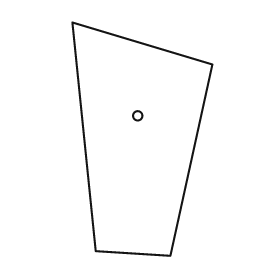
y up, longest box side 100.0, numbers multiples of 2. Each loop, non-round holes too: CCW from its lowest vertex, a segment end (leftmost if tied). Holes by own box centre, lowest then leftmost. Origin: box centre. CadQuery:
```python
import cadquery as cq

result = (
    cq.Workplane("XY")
    .moveTo(12.0, -50.0)
    .lineTo(30.0, 32.0)
    .lineTo(-30.0, 50.0)
    .lineTo(-20.0, -48.0)
    .close()
    .moveTo(-2.0, 10.0)
    .circle(2.0)
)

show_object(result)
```